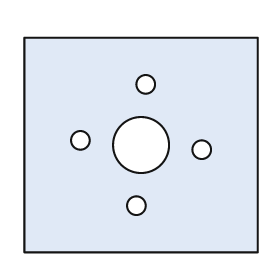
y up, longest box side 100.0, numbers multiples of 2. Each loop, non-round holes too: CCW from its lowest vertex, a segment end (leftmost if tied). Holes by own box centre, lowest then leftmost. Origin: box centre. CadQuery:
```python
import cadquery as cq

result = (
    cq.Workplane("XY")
    .moveTo(-50.0, -46.0)
    .lineTo(50.0, -46.0)
    .lineTo(50.0, 46.0)
    .lineTo(-50.0, 46.0)
    .close()
    .moveTo(-2.0, -26.0)
    .circle(4.0)
    .moveTo(26.0, -2.0)
    .circle(4.0)
    .moveTo(0.0, 0.0)
    .circle(12.0)
    .moveTo(-26.0, 2.0)
    .circle(4.0)
    .moveTo(2.0, 26.0)
    .circle(4.0)
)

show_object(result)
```